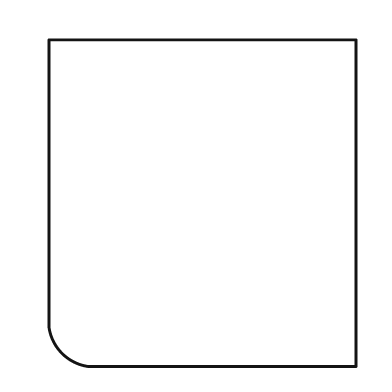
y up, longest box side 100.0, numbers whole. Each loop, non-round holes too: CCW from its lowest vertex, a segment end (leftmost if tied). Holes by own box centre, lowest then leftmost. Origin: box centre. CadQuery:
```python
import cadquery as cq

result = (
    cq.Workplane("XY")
    .moveTo(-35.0, -50.0)
    .lineTo(47.0, -50.0)
    .lineTo(47.0, 50.0)
    .lineTo(-47.0, 50.0)
    .lineTo(-47.0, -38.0)
    .threePointArc((-43.0, -46.0), (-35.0, -50.0))
    .close()
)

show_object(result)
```